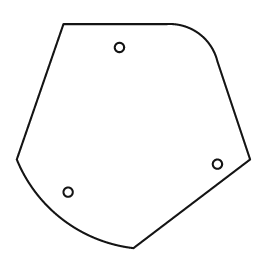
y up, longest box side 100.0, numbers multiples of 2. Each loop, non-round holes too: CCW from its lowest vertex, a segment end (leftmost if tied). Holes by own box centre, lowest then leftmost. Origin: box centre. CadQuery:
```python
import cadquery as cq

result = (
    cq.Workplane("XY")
    .moveTo(0.0, -48.0)
    .lineTo(50.0, -10.0)
    .lineTo(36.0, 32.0)
    .threePointArc((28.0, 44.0), (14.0, 48.0))
    .lineTo(-30.0, 48.0)
    .lineTo(-50.0, -10.0)
    .threePointArc((-30.0, -36.0), (0.0, -48.0))
    .close()
    .moveTo(-28.0, -24.0)
    .circle(2.0)
    .moveTo(36.0, -12.0)
    .circle(2.0)
    .moveTo(-6.0, 38.0)
    .circle(2.0)
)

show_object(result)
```